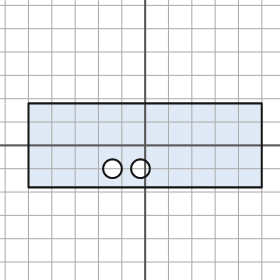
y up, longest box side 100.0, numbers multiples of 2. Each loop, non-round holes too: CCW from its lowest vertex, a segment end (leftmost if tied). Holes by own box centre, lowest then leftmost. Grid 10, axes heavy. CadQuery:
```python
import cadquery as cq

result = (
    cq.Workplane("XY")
    .moveTo(-50.0, -18.0)
    .lineTo(50.0, -18.0)
    .lineTo(50.0, 18.0)
    .lineTo(-50.0, 18.0)
    .close()
    .moveTo(-14.0, -10.0)
    .circle(4.0)
    .moveTo(-2.0, -10.0)
    .circle(4.0)
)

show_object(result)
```